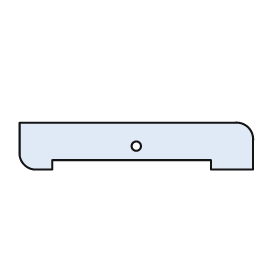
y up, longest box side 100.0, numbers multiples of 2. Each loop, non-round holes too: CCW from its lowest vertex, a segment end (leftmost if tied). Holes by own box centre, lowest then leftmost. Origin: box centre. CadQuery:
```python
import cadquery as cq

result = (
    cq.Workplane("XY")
    .moveTo(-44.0, -10.0)
    .lineTo(-36.0, -10.0)
    .lineTo(-36.0, -6.0)
    .lineTo(32.0, -6.0)
    .lineTo(32.0, -10.0)
    .lineTo(50.0, -10.0)
    .lineTo(50.0, 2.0)
    .threePointArc((48.0, 8.0), (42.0, 10.0))
    .lineTo(-50.0, 10.0)
    .lineTo(-50.0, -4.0)
    .threePointArc((-48.0, -8.0), (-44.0, -10.0))
    .close()
    .moveTo(0.0, 0.0)
    .circle(2.0)
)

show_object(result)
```